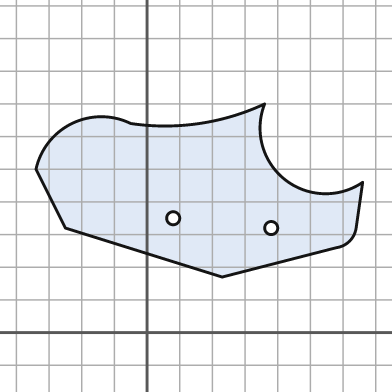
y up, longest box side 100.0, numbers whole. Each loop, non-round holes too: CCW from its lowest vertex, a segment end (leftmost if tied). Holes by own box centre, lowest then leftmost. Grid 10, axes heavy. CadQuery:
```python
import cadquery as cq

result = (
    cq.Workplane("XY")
    .moveTo(23.0, 17.0)
    .lineTo(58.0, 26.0)
    .threePointArc((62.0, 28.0), (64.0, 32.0))
    .lineTo(66.0, 46.0)
    .threePointArc((42.0, 47.0), (36.0, 70.0))
    .threePointArc((16.0, 64.0), (-5.0, 64.0))
    .threePointArc((-23.0, 64.0), (-34.0, 50.0))
    .lineTo(-25.0, 32.0)
    .close()
    .moveTo(38.0, 32.0)
    .circle(2.0)
    .moveTo(8.0, 35.0)
    .circle(2.0)
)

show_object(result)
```